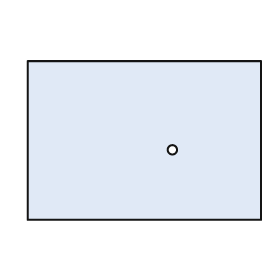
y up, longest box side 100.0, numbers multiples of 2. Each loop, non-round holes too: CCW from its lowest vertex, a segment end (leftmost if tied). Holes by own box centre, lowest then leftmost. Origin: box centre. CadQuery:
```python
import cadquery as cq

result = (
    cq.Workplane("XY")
    .moveTo(-50.0, -34.0)
    .lineTo(50.0, -34.0)
    .lineTo(50.0, 34.0)
    .lineTo(-50.0, 34.0)
    .close()
    .moveTo(12.0, -4.0)
    .circle(2.0)
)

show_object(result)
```